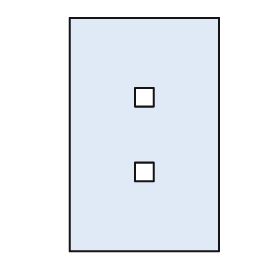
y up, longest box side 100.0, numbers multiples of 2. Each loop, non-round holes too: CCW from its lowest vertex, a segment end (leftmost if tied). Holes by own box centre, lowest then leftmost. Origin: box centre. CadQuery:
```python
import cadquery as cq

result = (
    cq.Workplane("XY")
    .moveTo(-32.0, -50.0)
    .lineTo(32.0, -50.0)
    .lineTo(32.0, 50.0)
    .lineTo(-32.0, 50.0)
    .close()
    .moveTo(-4.0, -20.0)
    .lineTo(4.0, -20.0)
    .lineTo(4.0, -12.0)
    .lineTo(-4.0, -12.0)
    .close()
    .moveTo(-4.0, 12.0)
    .lineTo(4.0, 12.0)
    .lineTo(4.0, 20.0)
    .lineTo(-4.0, 20.0)
    .close()
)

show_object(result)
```